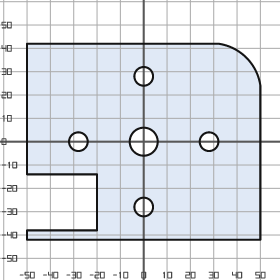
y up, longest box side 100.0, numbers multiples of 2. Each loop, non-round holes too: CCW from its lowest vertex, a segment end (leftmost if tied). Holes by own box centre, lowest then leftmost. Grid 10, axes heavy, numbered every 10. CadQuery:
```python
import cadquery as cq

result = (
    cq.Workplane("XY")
    .moveTo(-50.0, -42.0)
    .lineTo(50.0, -42.0)
    .lineTo(50.0, 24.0)
    .threePointArc((44.0, 36.0), (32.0, 42.0))
    .lineTo(-50.0, 42.0)
    .lineTo(-50.0, -14.0)
    .lineTo(-20.0, -14.0)
    .lineTo(-20.0, -38.0)
    .lineTo(-50.0, -38.0)
    .close()
    .moveTo(0.0, -28.0)
    .circle(4.0)
    .moveTo(-28.0, 0.0)
    .circle(4.0)
    .moveTo(0.0, 0.0)
    .circle(6.0)
    .moveTo(28.0, 0.0)
    .circle(4.0)
    .moveTo(0.0, 28.0)
    .circle(4.0)
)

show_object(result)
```